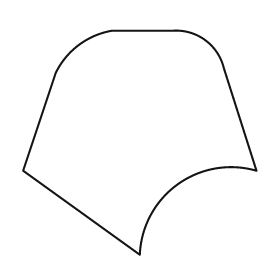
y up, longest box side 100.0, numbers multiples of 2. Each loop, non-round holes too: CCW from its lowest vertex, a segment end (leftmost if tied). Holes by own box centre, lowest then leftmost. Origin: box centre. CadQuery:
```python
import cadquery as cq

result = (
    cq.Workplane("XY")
    .moveTo(0.0, -48.0)
    .threePointArc((16.0, -18.0), (50.0, -12.0))
    .lineTo(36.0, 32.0)
    .threePointArc((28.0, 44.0), (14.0, 48.0))
    .lineTo(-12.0, 48.0)
    .threePointArc((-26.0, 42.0), (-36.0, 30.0))
    .lineTo(-50.0, -12.0)
    .close()
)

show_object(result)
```